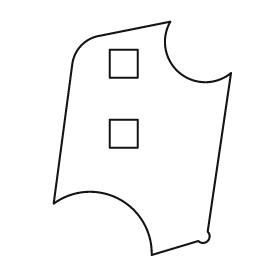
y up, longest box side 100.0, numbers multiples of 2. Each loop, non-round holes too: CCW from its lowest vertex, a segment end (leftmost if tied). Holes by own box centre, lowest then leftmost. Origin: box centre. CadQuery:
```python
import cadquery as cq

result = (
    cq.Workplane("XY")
    .moveTo(4.0, -50.0)
    .lineTo(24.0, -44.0)
    .threePointArc((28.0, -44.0), (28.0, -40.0))
    .lineTo(38.0, 28.0)
    .threePointArc((16.0, 28.0), (12.0, 50.0))
    .lineTo(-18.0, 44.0)
    .threePointArc((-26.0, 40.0), (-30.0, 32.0))
    .lineTo(-38.0, -28.0)
    .threePointArc((-10.0, -26.0), (4.0, -50.0))
    .close()
    .moveTo(-14.0, -4.0)
    .lineTo(-2.0, -4.0)
    .lineTo(-2.0, 8.0)
    .lineTo(-14.0, 8.0)
    .close()
    .moveTo(-14.0, 26.0)
    .lineTo(-2.0, 26.0)
    .lineTo(-2.0, 38.0)
    .lineTo(-14.0, 38.0)
    .close()
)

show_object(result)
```